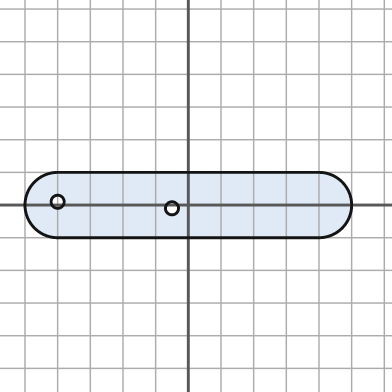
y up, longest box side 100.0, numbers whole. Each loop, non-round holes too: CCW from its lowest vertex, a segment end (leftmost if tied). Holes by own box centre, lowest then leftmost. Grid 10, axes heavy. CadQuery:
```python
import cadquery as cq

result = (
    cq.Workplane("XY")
    .moveTo(-40.0, -10.0)
    .lineTo(40.0, -10.0)
    .threePointArc((50.0, 0.0), (40.0, 10.0))
    .lineTo(-40.0, 10.0)
    .threePointArc((-50.0, 0.0), (-40.0, -10.0))
    .close()
    .moveTo(-5.0, -1.0)
    .circle(2.0)
    .moveTo(-40.0, 1.0)
    .circle(2.0)
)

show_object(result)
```